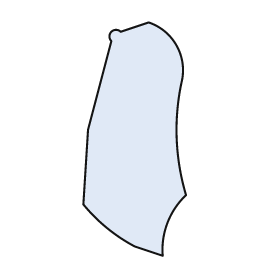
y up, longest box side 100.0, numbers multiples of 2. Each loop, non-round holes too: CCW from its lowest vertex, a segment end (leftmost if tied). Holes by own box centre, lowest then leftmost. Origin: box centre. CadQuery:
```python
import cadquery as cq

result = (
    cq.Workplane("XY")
    .moveTo(12.0, -50.0)
    .threePointArc((14.0, -36.0), (22.0, -24.0))
    .threePointArc((18.0, 0.0), (20.0, 24.0))
    .threePointArc((18.0, 40.0), (6.0, 50.0))
    .lineTo(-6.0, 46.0)
    .threePointArc((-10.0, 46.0), (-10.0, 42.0))
    .lineTo(-20.0, 4.0)
    .lineTo(-22.0, -28.0)
    .threePointArc((-12.0, -38.0), (0.0, -46.0))
    .close()
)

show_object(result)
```